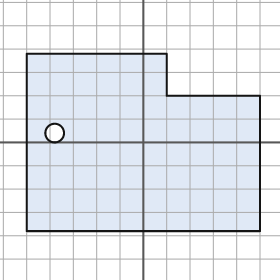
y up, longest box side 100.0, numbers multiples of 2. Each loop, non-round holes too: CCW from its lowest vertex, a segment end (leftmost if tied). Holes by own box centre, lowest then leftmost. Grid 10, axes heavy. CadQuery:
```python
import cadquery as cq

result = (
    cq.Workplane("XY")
    .moveTo(-50.0, -38.0)
    .lineTo(50.0, -38.0)
    .lineTo(50.0, 20.0)
    .lineTo(10.0, 20.0)
    .lineTo(10.0, 38.0)
    .lineTo(-50.0, 38.0)
    .close()
    .moveTo(-38.0, 4.0)
    .circle(4.0)
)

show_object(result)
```